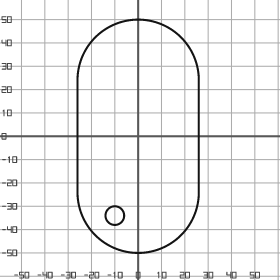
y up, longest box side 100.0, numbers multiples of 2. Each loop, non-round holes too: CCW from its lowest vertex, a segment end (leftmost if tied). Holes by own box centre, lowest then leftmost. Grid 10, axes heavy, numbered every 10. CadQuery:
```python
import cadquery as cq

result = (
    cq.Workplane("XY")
    .moveTo(-26.0, -24.0)
    .threePointArc((0.0, -50.0), (26.0, -24.0))
    .lineTo(26.0, 24.0)
    .threePointArc((0.0, 50.0), (-26.0, 24.0))
    .close()
    .moveTo(-10.0, -34.0)
    .circle(4.0)
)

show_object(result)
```